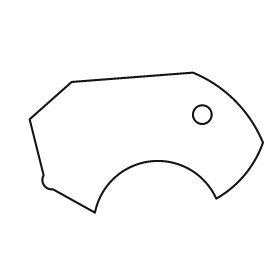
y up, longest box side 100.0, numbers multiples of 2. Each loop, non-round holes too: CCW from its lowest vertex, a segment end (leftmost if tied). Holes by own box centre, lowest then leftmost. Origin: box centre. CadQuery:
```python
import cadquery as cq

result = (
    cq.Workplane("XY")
    .moveTo(-22.0, -30.0)
    .threePointArc((2.0, -8.0), (30.0, -24.0))
    .threePointArc((42.0, -14.0), (50.0, 0.0))
    .threePointArc((38.0, 18.0), (20.0, 30.0))
    .lineTo(-32.0, 26.0)
    .lineTo(-50.0, 10.0)
    .lineTo(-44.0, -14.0)
    .threePointArc((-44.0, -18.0), (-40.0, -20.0))
    .close()
    .moveTo(24.0, 12.0)
    .circle(4.0)
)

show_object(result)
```